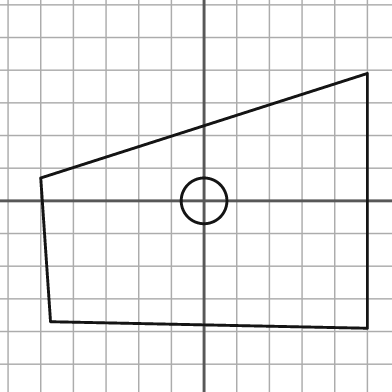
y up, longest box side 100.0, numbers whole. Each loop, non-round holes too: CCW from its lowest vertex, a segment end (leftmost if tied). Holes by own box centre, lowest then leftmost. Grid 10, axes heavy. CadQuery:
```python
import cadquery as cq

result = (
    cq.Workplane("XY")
    .moveTo(50.0, -39.0)
    .lineTo(50.0, 39.0)
    .lineTo(-50.0, 7.0)
    .lineTo(-47.0, -37.0)
    .close()
    .moveTo(0.0, 0.0)
    .circle(7.0)
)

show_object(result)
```